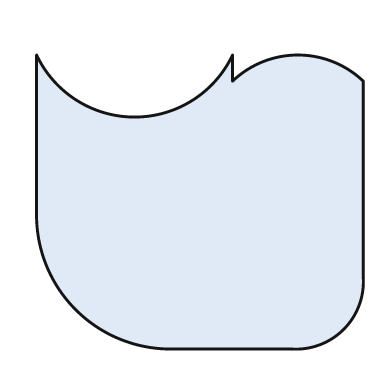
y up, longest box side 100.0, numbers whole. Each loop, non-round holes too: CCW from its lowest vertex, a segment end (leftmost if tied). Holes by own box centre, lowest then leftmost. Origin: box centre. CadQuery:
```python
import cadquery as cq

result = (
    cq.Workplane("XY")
    .moveTo(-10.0, -45.0)
    .lineTo(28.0, -45.0)
    .threePointArc((44.0, -39.0), (50.0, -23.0))
    .lineTo(50.0, 37.0)
    .threePointArc((30.0, 45.0), (10.0, 37.0))
    .lineTo(10.0, 45.0)
    .threePointArc((-20.0, 26.0), (-50.0, 45.0))
    .lineTo(-50.0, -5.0)
    .threePointArc((-38.0, -33.0), (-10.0, -45.0))
    .close()
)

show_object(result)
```